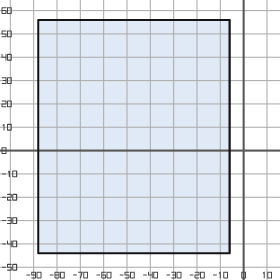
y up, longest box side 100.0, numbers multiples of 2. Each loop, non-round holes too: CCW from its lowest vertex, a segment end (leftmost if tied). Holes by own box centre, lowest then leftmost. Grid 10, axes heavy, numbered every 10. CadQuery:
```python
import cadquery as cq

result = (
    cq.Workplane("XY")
    .moveTo(-88.0, -44.0)
    .lineTo(-6.0, -44.0)
    .lineTo(-6.0, 56.0)
    .lineTo(-88.0, 56.0)
    .close()
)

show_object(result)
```